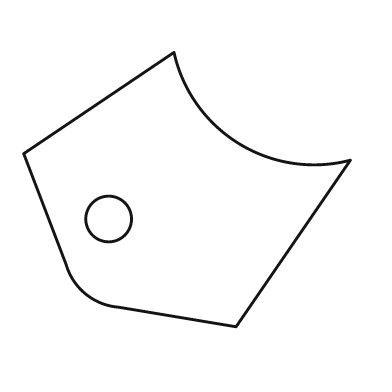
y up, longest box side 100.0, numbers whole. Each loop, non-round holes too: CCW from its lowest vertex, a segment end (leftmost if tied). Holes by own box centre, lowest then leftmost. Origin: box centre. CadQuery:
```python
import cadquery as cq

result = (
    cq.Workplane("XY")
    .moveTo(15.0, -42.0)
    .lineTo(50.0, 9.0)
    .threePointArc((16.0, 14.0), (-4.0, 42.0))
    .lineTo(-50.0, 11.0)
    .lineTo(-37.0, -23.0)
    .threePointArc((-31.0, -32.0), (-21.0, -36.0))
    .close()
    .moveTo(-24.0, -9.0)
    .circle(7.0)
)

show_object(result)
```